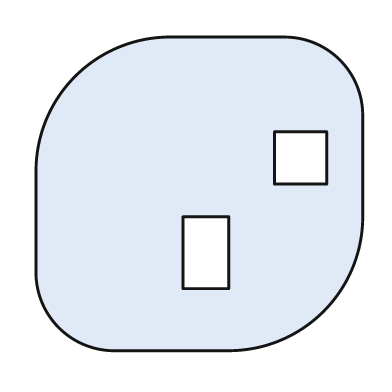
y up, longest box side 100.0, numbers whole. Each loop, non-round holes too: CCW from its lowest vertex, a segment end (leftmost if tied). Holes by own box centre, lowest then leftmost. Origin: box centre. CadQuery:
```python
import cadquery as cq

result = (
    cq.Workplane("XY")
    .moveTo(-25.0, -48.0)
    .lineTo(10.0, -48.0)
    .threePointArc((38.0, -36.0), (50.0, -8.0))
    .lineTo(50.0, 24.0)
    .threePointArc((43.0, 41.0), (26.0, 48.0))
    .lineTo(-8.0, 48.0)
    .threePointArc((-38.0, 36.0), (-50.0, 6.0))
    .lineTo(-50.0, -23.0)
    .threePointArc((-43.0, -41.0), (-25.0, -48.0))
    .close()
    .moveTo(-5.0, -29.0)
    .lineTo(9.0, -29.0)
    .lineTo(9.0, -7.0)
    .lineTo(-5.0, -7.0)
    .close()
    .moveTo(23.0, 3.0)
    .lineTo(39.0, 3.0)
    .lineTo(39.0, 19.0)
    .lineTo(23.0, 19.0)
    .close()
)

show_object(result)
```